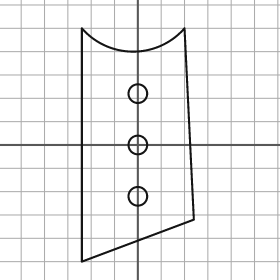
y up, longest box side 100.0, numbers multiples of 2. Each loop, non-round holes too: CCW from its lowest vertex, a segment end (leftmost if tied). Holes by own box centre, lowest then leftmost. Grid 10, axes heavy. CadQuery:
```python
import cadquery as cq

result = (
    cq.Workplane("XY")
    .moveTo(-24.0, -50.0)
    .lineTo(24.0, -32.0)
    .lineTo(20.0, 50.0)
    .threePointArc((-2.0, 40.0), (-24.0, 50.0))
    .close()
    .moveTo(0.0, -22.0)
    .circle(4.0)
    .moveTo(0.0, 0.0)
    .circle(4.0)
    .moveTo(0.0, 22.0)
    .circle(4.0)
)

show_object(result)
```